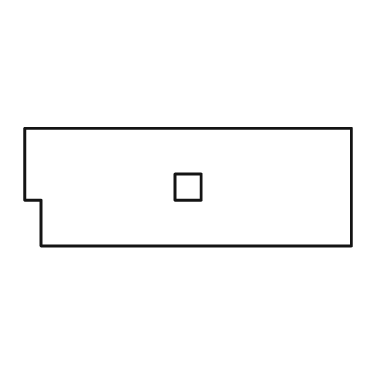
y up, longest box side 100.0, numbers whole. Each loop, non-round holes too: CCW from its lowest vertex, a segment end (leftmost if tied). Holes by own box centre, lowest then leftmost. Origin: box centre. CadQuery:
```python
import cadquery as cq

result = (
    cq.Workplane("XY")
    .moveTo(-45.0, -18.0)
    .lineTo(50.0, -18.0)
    .lineTo(50.0, 18.0)
    .lineTo(-50.0, 18.0)
    .lineTo(-50.0, -4.0)
    .lineTo(-45.0, -4.0)
    .close()
    .moveTo(-4.0, -4.0)
    .lineTo(4.0, -4.0)
    .lineTo(4.0, 4.0)
    .lineTo(-4.0, 4.0)
    .close()
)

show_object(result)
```